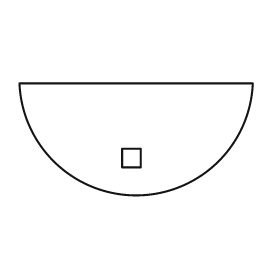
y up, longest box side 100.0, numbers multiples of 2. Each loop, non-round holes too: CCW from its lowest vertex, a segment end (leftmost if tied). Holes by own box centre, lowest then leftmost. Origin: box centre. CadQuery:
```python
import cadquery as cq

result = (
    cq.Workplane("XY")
    .moveTo(-50.0, 24.0)
    .threePointArc((0.0, -24.0), (50.0, 24.0))
    .close()
    .moveTo(-6.0, -12.0)
    .lineTo(2.0, -12.0)
    .lineTo(2.0, -4.0)
    .lineTo(-6.0, -4.0)
    .close()
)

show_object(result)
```